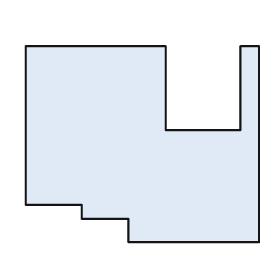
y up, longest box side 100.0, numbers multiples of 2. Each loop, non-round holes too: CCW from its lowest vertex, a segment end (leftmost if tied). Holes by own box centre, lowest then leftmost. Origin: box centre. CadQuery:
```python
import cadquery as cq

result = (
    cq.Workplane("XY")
    .moveTo(-6.0, -42.0)
    .lineTo(50.0, -42.0)
    .lineTo(50.0, 42.0)
    .lineTo(42.0, 42.0)
    .lineTo(42.0, 6.0)
    .lineTo(10.0, 6.0)
    .lineTo(10.0, 42.0)
    .lineTo(-50.0, 42.0)
    .lineTo(-50.0, -26.0)
    .lineTo(-26.0, -26.0)
    .lineTo(-26.0, -32.0)
    .lineTo(-6.0, -32.0)
    .close()
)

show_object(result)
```